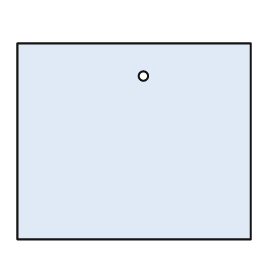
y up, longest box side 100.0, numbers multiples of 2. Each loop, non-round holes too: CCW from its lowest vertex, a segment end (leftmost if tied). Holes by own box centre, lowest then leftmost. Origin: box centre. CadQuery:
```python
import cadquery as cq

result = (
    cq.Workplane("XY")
    .moveTo(-50.0, -42.0)
    .lineTo(50.0, -42.0)
    .lineTo(50.0, 42.0)
    .lineTo(-50.0, 42.0)
    .close()
    .moveTo(4.0, 28.0)
    .circle(2.0)
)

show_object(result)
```